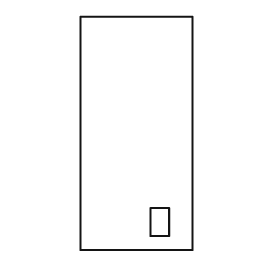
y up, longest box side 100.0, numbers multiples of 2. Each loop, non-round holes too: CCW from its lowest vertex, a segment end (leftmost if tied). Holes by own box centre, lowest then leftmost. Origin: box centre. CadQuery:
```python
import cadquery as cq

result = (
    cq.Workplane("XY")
    .moveTo(-24.0, -50.0)
    .lineTo(24.0, -50.0)
    .lineTo(24.0, 50.0)
    .lineTo(-24.0, 50.0)
    .close()
    .moveTo(6.0, -44.0)
    .lineTo(14.0, -44.0)
    .lineTo(14.0, -32.0)
    .lineTo(6.0, -32.0)
    .close()
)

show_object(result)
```